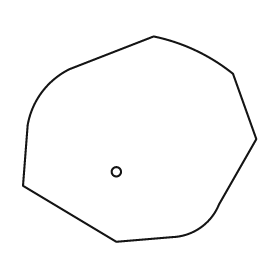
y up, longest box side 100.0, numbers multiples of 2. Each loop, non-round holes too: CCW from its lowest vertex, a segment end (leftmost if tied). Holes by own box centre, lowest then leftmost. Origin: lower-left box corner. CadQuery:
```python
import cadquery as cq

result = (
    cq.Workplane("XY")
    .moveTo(40.0, 0.0)
    .lineTo(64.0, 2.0)
    .threePointArc((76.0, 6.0), (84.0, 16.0))
    .lineTo(100.0, 44.0)
    .lineTo(90.0, 72.0)
    .threePointArc((74.0, 82.0), (56.0, 88.0))
    .lineTo(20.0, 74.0)
    .threePointArc((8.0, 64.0), (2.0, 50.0))
    .lineTo(0.0, 24.0)
    .close()
    .moveTo(40.0, 30.0)
    .circle(2.0)
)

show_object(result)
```